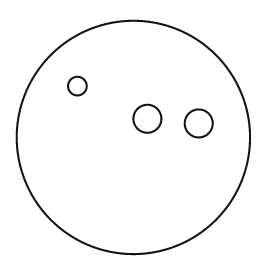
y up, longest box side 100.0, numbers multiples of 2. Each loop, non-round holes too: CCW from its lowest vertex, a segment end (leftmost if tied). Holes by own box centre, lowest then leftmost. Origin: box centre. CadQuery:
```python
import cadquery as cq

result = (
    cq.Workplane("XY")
    .moveTo(0.0, 0.0)
    .circle(50.0)
    .moveTo(28.0, 6.0)
    .circle(6.0)
    .moveTo(6.0, 8.0)
    .circle(6.0)
    .moveTo(-24.0, 22.0)
    .circle(4.0)
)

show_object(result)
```